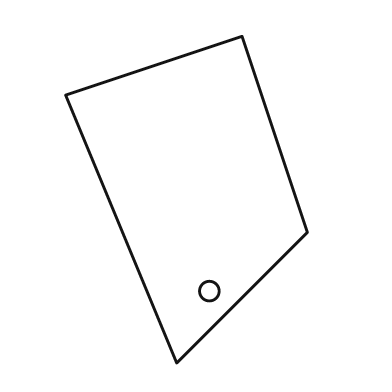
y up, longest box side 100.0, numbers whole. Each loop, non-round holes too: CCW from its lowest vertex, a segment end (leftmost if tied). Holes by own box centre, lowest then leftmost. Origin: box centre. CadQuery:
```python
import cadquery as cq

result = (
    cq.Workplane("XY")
    .moveTo(-3.0, -50.0)
    .lineTo(37.0, -10.0)
    .lineTo(17.0, 50.0)
    .lineTo(-37.0, 32.0)
    .close()
    .moveTo(7.0, -28.0)
    .circle(3.0)
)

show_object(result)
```